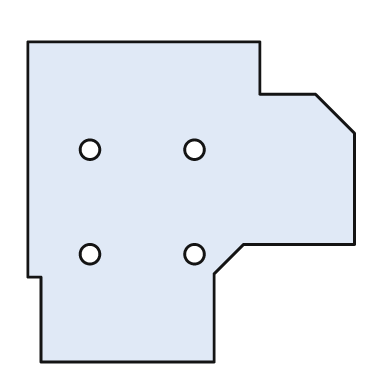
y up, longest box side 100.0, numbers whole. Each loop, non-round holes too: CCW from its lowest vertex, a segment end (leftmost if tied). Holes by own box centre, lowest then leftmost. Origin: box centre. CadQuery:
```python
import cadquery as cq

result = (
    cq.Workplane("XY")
    .moveTo(-46.0, -49.0)
    .lineTo(7.0, -49.0)
    .lineTo(7.0, -22.0)
    .lineTo(16.0, -13.0)
    .lineTo(50.0, -13.0)
    .lineTo(50.0, 21.0)
    .lineTo(38.0, 33.0)
    .lineTo(21.0, 33.0)
    .lineTo(21.0, 49.0)
    .lineTo(-50.0, 49.0)
    .lineTo(-50.0, -23.0)
    .lineTo(-46.0, -23.0)
    .close()
    .moveTo(-31.0, -16.0)
    .circle(3.0)
    .moveTo(1.0, -16.0)
    .circle(3.0)
    .moveTo(-31.0, 16.0)
    .circle(3.0)
    .moveTo(1.0, 16.0)
    .circle(3.0)
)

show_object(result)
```